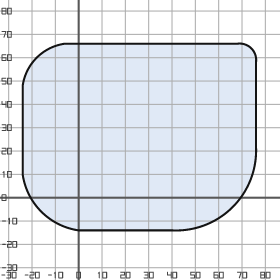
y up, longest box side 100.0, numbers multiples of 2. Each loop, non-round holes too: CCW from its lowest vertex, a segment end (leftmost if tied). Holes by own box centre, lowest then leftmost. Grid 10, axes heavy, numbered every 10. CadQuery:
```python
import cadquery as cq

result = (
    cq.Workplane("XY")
    .moveTo(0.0, -14.0)
    .lineTo(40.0, -14.0)
    .threePointArc((66.0, -4.0), (76.0, 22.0))
    .lineTo(76.0, 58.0)
    .threePointArc((74.0, 64.0), (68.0, 66.0))
    .lineTo(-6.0, 66.0)
    .threePointArc((-18.0, 60.0), (-24.0, 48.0))
    .lineTo(-24.0, 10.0)
    .threePointArc((-16.0, -6.0), (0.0, -14.0))
    .close()
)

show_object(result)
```